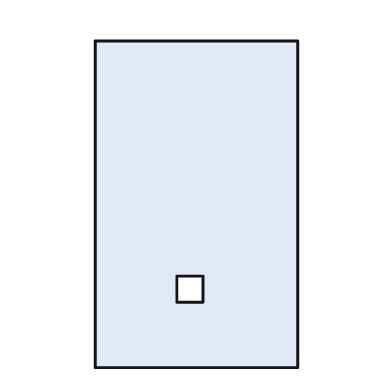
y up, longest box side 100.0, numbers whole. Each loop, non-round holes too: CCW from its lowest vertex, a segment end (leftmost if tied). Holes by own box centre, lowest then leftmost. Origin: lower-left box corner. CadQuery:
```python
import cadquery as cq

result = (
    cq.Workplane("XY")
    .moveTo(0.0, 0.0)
    .lineTo(62.0, 0.0)
    .lineTo(62.0, 100.0)
    .lineTo(0.0, 100.0)
    .close()
    .moveTo(25.0, 20.0)
    .lineTo(33.0, 20.0)
    .lineTo(33.0, 28.0)
    .lineTo(25.0, 28.0)
    .close()
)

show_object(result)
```